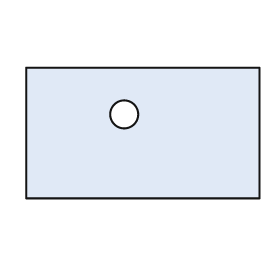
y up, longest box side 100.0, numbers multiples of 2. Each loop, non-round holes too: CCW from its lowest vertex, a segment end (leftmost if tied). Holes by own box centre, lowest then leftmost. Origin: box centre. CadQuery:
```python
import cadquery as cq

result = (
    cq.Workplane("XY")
    .moveTo(-50.0, -28.0)
    .lineTo(50.0, -28.0)
    .lineTo(50.0, 28.0)
    .lineTo(-50.0, 28.0)
    .close()
    .moveTo(-8.0, 8.0)
    .circle(6.0)
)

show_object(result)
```